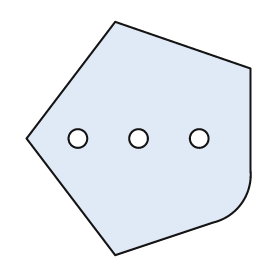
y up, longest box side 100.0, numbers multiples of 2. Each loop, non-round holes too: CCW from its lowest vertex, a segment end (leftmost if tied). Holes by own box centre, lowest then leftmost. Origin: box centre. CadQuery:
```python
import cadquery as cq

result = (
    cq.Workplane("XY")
    .moveTo(-10.0, -50.0)
    .lineTo(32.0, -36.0)
    .threePointArc((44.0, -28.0), (48.0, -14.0))
    .lineTo(48.0, 30.0)
    .lineTo(-10.0, 50.0)
    .lineTo(-48.0, 0.0)
    .close()
    .moveTo(-26.0, 0.0)
    .circle(4.0)
    .moveTo(0.0, 0.0)
    .circle(4.0)
    .moveTo(26.0, 0.0)
    .circle(4.0)
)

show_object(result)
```